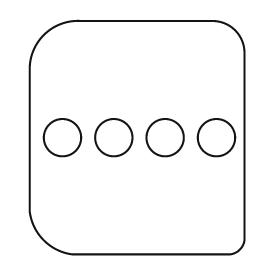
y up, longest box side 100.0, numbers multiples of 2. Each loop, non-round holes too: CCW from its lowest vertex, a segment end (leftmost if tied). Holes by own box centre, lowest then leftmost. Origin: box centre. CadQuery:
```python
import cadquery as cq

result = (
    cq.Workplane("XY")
    .moveTo(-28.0, -50.0)
    .lineTo(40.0, -50.0)
    .threePointArc((44.0, -48.0), (46.0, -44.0))
    .lineTo(46.0, 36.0)
    .threePointArc((42.0, 46.0), (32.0, 50.0))
    .lineTo(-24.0, 50.0)
    .threePointArc((-40.0, 44.0), (-46.0, 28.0))
    .lineTo(-46.0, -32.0)
    .threePointArc((-40.0, -44.0), (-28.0, -50.0))
    .close()
    .moveTo(-32.0, 0.0)
    .circle(8.0)
    .moveTo(-10.0, 0.0)
    .circle(8.0)
    .moveTo(12.0, 0.0)
    .circle(8.0)
    .moveTo(34.0, 0.0)
    .circle(8.0)
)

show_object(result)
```